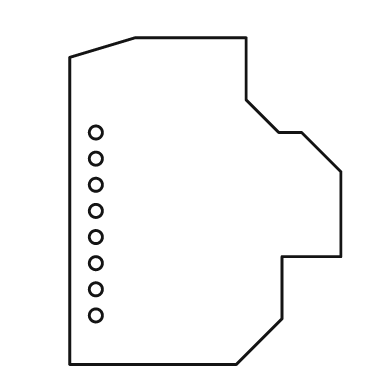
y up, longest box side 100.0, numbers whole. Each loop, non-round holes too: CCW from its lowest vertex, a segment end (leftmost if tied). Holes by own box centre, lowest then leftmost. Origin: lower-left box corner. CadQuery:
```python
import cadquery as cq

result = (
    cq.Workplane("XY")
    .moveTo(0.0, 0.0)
    .lineTo(51.0, 0.0)
    .lineTo(65.0, 14.0)
    .lineTo(65.0, 33.0)
    .lineTo(83.0, 33.0)
    .lineTo(83.0, 59.0)
    .lineTo(71.0, 71.0)
    .lineTo(64.0, 71.0)
    .lineTo(54.0, 81.0)
    .lineTo(54.0, 100.0)
    .lineTo(20.0, 100.0)
    .lineTo(0.0, 94.0)
    .close()
    .moveTo(8.0, 15.0)
    .circle(2.0)
    .moveTo(8.0, 23.0)
    .circle(2.0)
    .moveTo(8.0, 31.0)
    .circle(2.0)
    .moveTo(8.0, 39.0)
    .circle(2.0)
    .moveTo(8.0, 47.0)
    .circle(2.0)
    .moveTo(8.0, 55.0)
    .circle(2.0)
    .moveTo(8.0, 63.0)
    .circle(2.0)
    .moveTo(8.0, 71.0)
    .circle(2.0)
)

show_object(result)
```